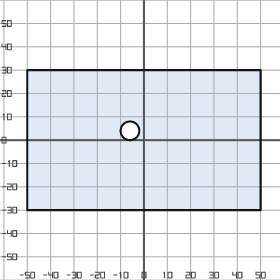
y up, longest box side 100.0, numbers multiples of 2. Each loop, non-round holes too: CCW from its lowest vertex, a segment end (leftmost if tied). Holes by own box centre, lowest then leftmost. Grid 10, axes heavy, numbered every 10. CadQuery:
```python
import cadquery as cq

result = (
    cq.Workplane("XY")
    .moveTo(-50.0, -30.0)
    .lineTo(50.0, -30.0)
    .lineTo(50.0, 30.0)
    .lineTo(-50.0, 30.0)
    .close()
    .moveTo(-6.0, 4.0)
    .circle(4.0)
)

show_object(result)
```